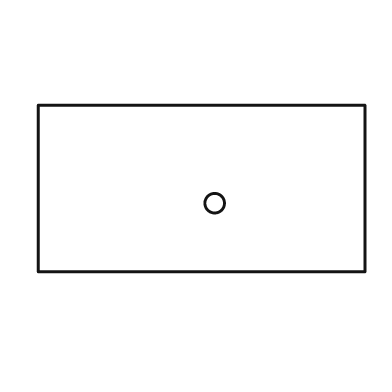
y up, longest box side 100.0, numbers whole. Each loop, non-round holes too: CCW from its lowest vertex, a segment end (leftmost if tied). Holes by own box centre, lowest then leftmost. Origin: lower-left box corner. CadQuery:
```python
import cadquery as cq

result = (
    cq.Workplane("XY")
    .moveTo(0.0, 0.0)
    .lineTo(100.0, 0.0)
    .lineTo(100.0, 51.0)
    .lineTo(0.0, 51.0)
    .close()
    .moveTo(54.0, 21.0)
    .circle(3.0)
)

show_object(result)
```